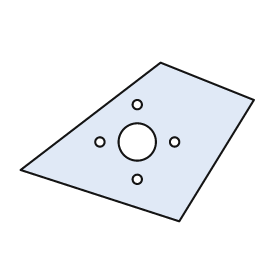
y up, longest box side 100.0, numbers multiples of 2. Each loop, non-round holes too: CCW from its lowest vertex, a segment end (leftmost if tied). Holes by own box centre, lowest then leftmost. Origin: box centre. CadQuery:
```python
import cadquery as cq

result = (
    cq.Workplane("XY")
    .moveTo(18.0, -34.0)
    .lineTo(50.0, 18.0)
    .lineTo(10.0, 34.0)
    .lineTo(-50.0, -12.0)
    .close()
    .moveTo(0.0, -16.0)
    .circle(2.0)
    .moveTo(-16.0, 0.0)
    .circle(2.0)
    .moveTo(0.0, 0.0)
    .circle(8.0)
    .moveTo(16.0, 0.0)
    .circle(2.0)
    .moveTo(0.0, 16.0)
    .circle(2.0)
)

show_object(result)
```